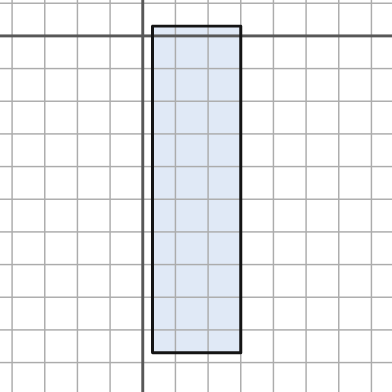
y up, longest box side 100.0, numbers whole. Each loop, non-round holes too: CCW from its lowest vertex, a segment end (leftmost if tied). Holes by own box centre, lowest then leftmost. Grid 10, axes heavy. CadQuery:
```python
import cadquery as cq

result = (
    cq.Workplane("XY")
    .moveTo(3.0, -97.0)
    .lineTo(30.0, -97.0)
    .lineTo(30.0, 3.0)
    .lineTo(3.0, 3.0)
    .close()
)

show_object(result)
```